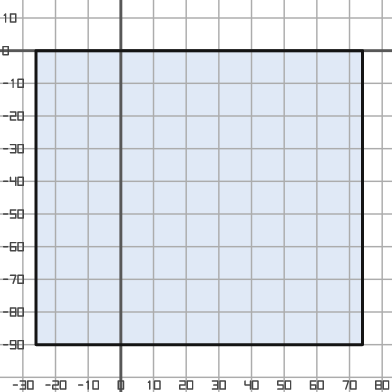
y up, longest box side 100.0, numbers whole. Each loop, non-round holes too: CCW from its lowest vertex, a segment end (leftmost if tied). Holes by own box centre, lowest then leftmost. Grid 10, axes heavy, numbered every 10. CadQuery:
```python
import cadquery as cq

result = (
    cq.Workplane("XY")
    .moveTo(-26.0, -90.0)
    .lineTo(74.0, -90.0)
    .lineTo(74.0, 0.0)
    .lineTo(-26.0, 0.0)
    .close()
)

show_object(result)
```